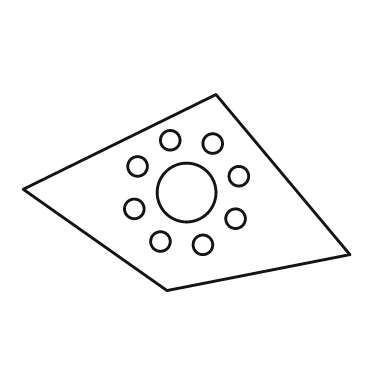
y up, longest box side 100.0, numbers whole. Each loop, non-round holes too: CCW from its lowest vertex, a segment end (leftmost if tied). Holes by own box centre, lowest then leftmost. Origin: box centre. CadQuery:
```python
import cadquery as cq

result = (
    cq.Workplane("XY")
    .moveTo(-6.0, -30.0)
    .lineTo(50.0, -19.0)
    .lineTo(9.0, 30.0)
    .lineTo(-50.0, 1.0)
    .close()
    .moveTo(5.0, -16.0)
    .circle(3.0)
    .moveTo(-8.0, -15.0)
    .circle(3.0)
    .moveTo(15.0, -8.0)
    .circle(3.0)
    .moveTo(-16.0, -5.0)
    .circle(3.0)
    .moveTo(0.0, 0.0)
    .circle(9.0)
    .moveTo(16.0, 5.0)
    .circle(3.0)
    .moveTo(-15.0, 8.0)
    .circle(3.0)
    .moveTo(8.0, 15.0)
    .circle(3.0)
    .moveTo(-5.0, 16.0)
    .circle(3.0)
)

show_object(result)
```